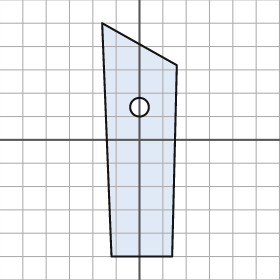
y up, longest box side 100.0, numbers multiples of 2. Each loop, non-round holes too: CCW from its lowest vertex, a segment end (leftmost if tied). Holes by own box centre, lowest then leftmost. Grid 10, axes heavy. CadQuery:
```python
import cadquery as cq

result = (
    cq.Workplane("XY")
    .moveTo(-12.0, -50.0)
    .lineTo(14.0, -50.0)
    .lineTo(16.0, 32.0)
    .lineTo(-16.0, 50.0)
    .close()
    .moveTo(0.0, 14.0)
    .circle(4.0)
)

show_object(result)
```